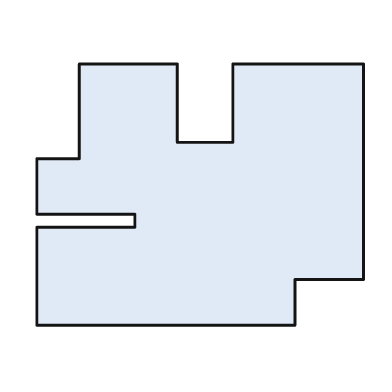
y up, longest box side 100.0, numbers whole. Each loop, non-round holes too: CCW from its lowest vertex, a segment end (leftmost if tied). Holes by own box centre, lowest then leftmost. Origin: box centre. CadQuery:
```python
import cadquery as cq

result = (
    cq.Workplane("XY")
    .moveTo(-50.0, -40.0)
    .lineTo(29.0, -40.0)
    .lineTo(29.0, -26.0)
    .lineTo(50.0, -26.0)
    .lineTo(50.0, 40.0)
    .lineTo(10.0, 40.0)
    .lineTo(10.0, 16.0)
    .lineTo(-7.0, 16.0)
    .lineTo(-7.0, 40.0)
    .lineTo(-37.0, 40.0)
    .lineTo(-37.0, 11.0)
    .lineTo(-50.0, 11.0)
    .lineTo(-50.0, -6.0)
    .lineTo(-20.0, -6.0)
    .lineTo(-20.0, -10.0)
    .lineTo(-50.0, -10.0)
    .close()
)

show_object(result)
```